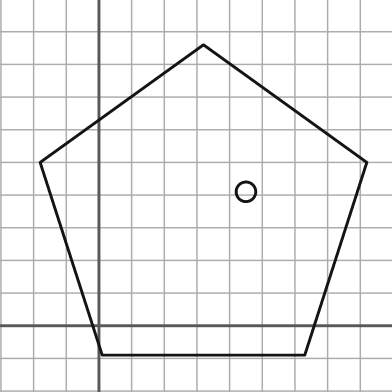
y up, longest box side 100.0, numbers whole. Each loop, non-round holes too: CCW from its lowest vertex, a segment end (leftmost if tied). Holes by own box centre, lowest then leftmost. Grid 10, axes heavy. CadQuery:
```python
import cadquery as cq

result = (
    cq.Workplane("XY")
    .moveTo(1.0, -9.0)
    .lineTo(63.0, -9.0)
    .lineTo(82.0, 50.0)
    .lineTo(32.0, 86.0)
    .lineTo(-18.0, 50.0)
    .close()
    .moveTo(45.0, 41.0)
    .circle(3.0)
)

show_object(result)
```